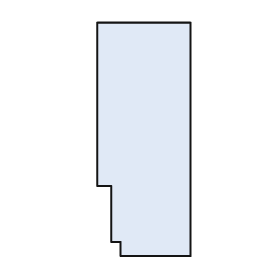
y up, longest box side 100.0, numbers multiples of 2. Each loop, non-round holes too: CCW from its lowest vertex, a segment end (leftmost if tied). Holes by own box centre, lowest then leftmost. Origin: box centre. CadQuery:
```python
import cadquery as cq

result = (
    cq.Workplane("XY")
    .moveTo(-10.0, -50.0)
    .lineTo(20.0, -50.0)
    .lineTo(20.0, 50.0)
    .lineTo(-20.0, 50.0)
    .lineTo(-20.0, -20.0)
    .lineTo(-14.0, -20.0)
    .lineTo(-14.0, -44.0)
    .lineTo(-10.0, -44.0)
    .close()
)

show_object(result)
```